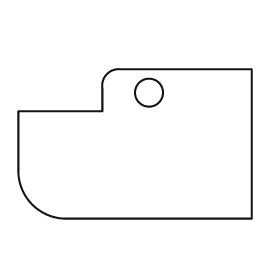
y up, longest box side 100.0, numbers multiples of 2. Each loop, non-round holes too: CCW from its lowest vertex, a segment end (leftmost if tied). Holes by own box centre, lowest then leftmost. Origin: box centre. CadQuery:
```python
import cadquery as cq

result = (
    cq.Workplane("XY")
    .moveTo(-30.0, -32.0)
    .lineTo(50.0, -32.0)
    .lineTo(50.0, 32.0)
    .lineTo(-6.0, 32.0)
    .threePointArc((-12.0, 30.0), (-14.0, 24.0))
    .lineTo(-14.0, 14.0)
    .lineTo(-50.0, 14.0)
    .lineTo(-50.0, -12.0)
    .threePointArc((-44.0, -26.0), (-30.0, -32.0))
    .close()
    .moveTo(6.0, 22.0)
    .circle(6.0)
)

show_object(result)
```